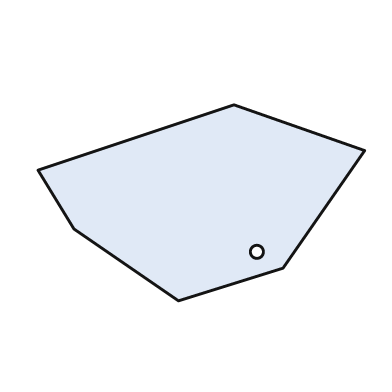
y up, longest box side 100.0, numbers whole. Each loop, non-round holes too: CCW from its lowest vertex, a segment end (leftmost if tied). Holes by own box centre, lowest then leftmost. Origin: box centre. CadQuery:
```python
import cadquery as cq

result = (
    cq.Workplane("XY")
    .moveTo(-7.0, -30.0)
    .lineTo(25.0, -20.0)
    .lineTo(50.0, 16.0)
    .lineTo(10.0, 30.0)
    .lineTo(-50.0, 10.0)
    .lineTo(-39.0, -8.0)
    .close()
    .moveTo(17.0, -15.0)
    .circle(2.0)
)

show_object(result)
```